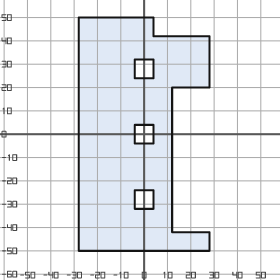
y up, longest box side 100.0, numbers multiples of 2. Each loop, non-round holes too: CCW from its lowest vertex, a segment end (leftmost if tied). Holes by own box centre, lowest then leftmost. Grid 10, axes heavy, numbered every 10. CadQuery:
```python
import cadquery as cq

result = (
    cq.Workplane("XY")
    .moveTo(-28.0, -50.0)
    .lineTo(28.0, -50.0)
    .lineTo(28.0, -42.0)
    .lineTo(12.0, -42.0)
    .lineTo(12.0, 20.0)
    .lineTo(28.0, 20.0)
    .lineTo(28.0, 42.0)
    .lineTo(4.0, 42.0)
    .lineTo(4.0, 50.0)
    .lineTo(-28.0, 50.0)
    .close()
    .moveTo(-4.0, -32.0)
    .lineTo(4.0, -32.0)
    .lineTo(4.0, -24.0)
    .lineTo(-4.0, -24.0)
    .close()
    .moveTo(-4.0, -4.0)
    .lineTo(4.0, -4.0)
    .lineTo(4.0, 4.0)
    .lineTo(-4.0, 4.0)
    .close()
    .moveTo(-4.0, 24.0)
    .lineTo(4.0, 24.0)
    .lineTo(4.0, 32.0)
    .lineTo(-4.0, 32.0)
    .close()
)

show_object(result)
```